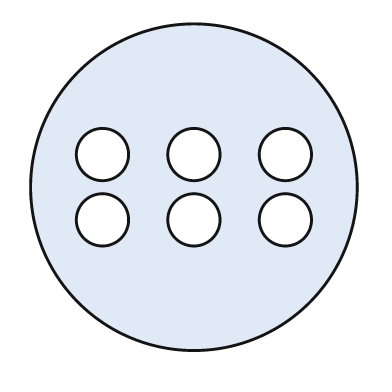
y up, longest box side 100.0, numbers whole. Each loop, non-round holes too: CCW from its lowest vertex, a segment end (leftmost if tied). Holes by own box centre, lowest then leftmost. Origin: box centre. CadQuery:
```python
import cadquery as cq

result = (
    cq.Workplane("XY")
    .moveTo(0.0, 0.0)
    .circle(50.0)
    .moveTo(-28.0, -10.0)
    .circle(8.0)
    .moveTo(0.0, -10.0)
    .circle(8.0)
    .moveTo(28.0, -10.0)
    .circle(8.0)
    .moveTo(-28.0, 10.0)
    .circle(8.0)
    .moveTo(0.0, 10.0)
    .circle(8.0)
    .moveTo(28.0, 10.0)
    .circle(8.0)
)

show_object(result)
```